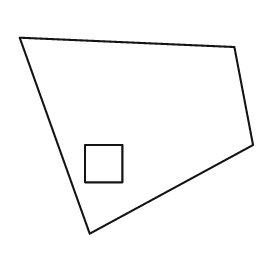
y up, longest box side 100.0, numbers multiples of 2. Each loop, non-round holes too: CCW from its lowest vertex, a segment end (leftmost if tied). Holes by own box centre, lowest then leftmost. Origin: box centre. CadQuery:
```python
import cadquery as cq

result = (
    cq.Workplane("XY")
    .moveTo(-20.0, -42.0)
    .lineTo(50.0, -4.0)
    .lineTo(42.0, 38.0)
    .lineTo(-50.0, 42.0)
    .close()
    .moveTo(-22.0, -20.0)
    .lineTo(-6.0, -20.0)
    .lineTo(-6.0, -4.0)
    .lineTo(-22.0, -4.0)
    .close()
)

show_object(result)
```